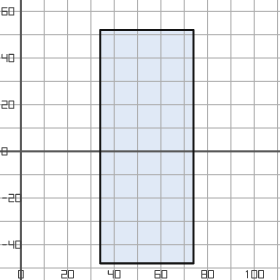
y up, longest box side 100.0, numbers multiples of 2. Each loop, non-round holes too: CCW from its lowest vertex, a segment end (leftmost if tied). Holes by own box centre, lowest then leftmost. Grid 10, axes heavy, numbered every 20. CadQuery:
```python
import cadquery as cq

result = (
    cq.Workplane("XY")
    .moveTo(34.0, -48.0)
    .lineTo(74.0, -48.0)
    .lineTo(74.0, 52.0)
    .lineTo(34.0, 52.0)
    .close()
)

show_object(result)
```